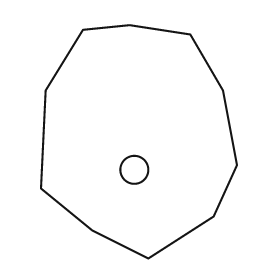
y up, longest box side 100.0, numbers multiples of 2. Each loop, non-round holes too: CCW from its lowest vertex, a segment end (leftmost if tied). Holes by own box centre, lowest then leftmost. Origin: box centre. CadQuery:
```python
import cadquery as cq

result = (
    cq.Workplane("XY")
    .moveTo(4.0, -50.0)
    .lineTo(32.0, -32.0)
    .lineTo(42.0, -10.0)
    .lineTo(36.0, 22.0)
    .lineTo(22.0, 46.0)
    .lineTo(-4.0, 50.0)
    .lineTo(-24.0, 48.0)
    .lineTo(-40.0, 22.0)
    .lineTo(-42.0, -20.0)
    .lineTo(-20.0, -38.0)
    .close()
    .moveTo(-2.0, -12.0)
    .circle(6.0)
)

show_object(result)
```